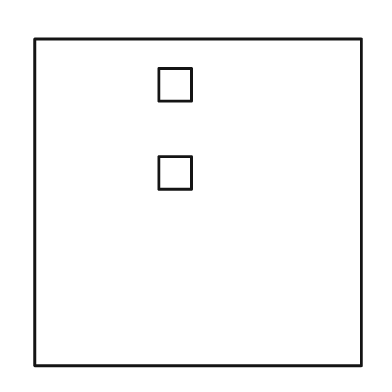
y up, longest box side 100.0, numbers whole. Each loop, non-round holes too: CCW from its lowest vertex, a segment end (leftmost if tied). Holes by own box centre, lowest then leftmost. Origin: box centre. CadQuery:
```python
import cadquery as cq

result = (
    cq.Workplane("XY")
    .moveTo(-50.0, -50.0)
    .lineTo(50.0, -50.0)
    .lineTo(50.0, 50.0)
    .lineTo(-50.0, 50.0)
    .close()
    .moveTo(-12.0, 4.0)
    .lineTo(-2.0, 4.0)
    .lineTo(-2.0, 14.0)
    .lineTo(-12.0, 14.0)
    .close()
    .moveTo(-12.0, 31.0)
    .lineTo(-2.0, 31.0)
    .lineTo(-2.0, 41.0)
    .lineTo(-12.0, 41.0)
    .close()
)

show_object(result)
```